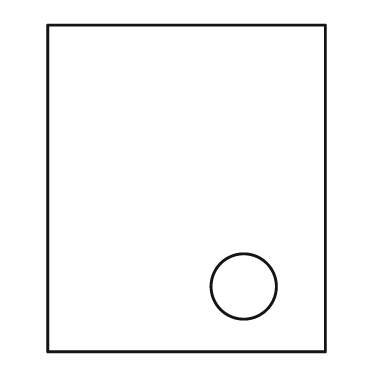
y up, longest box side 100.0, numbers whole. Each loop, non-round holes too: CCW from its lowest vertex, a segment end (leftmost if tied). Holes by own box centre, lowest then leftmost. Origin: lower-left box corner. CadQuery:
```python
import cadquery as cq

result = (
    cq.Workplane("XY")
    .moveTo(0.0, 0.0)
    .lineTo(85.0, 0.0)
    .lineTo(85.0, 100.0)
    .lineTo(0.0, 100.0)
    .close()
    .moveTo(60.0, 20.0)
    .circle(10.0)
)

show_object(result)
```